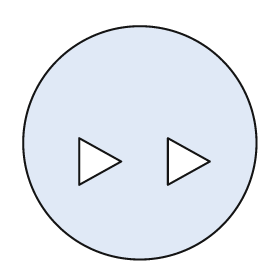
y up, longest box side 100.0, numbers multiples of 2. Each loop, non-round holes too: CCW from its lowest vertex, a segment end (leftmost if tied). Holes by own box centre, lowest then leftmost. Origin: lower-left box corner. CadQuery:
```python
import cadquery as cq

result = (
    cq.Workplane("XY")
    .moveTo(50.0, 50.0)
    .circle(50.0)
    .moveTo(24.0, 32.0)
    .lineTo(42.0, 42.0)
    .lineTo(24.0, 52.0)
    .close()
    .moveTo(62.0, 32.0)
    .lineTo(80.0, 42.0)
    .lineTo(62.0, 52.0)
    .close()
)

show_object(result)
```